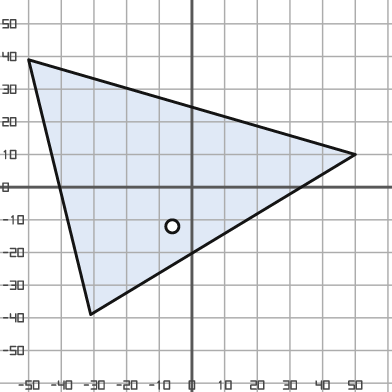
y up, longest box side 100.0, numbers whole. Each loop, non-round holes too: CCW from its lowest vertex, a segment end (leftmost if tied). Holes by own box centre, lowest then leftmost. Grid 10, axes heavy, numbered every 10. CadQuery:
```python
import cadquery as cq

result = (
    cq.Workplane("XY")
    .moveTo(-31.0, -39.0)
    .lineTo(50.0, 10.0)
    .lineTo(-50.0, 39.0)
    .close()
    .moveTo(-6.0, -12.0)
    .circle(2.0)
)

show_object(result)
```